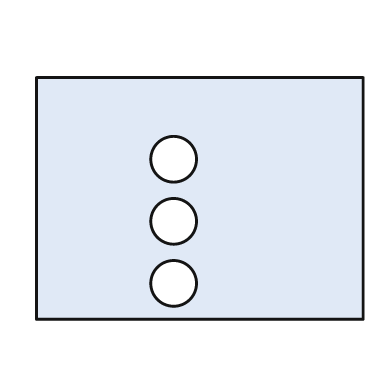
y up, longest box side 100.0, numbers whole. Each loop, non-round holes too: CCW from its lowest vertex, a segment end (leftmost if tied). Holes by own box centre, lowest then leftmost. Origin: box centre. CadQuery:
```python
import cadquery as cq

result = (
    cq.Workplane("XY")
    .moveTo(-50.0, -37.0)
    .lineTo(50.0, -37.0)
    .lineTo(50.0, 37.0)
    .lineTo(-50.0, 37.0)
    .close()
    .moveTo(-8.0, -26.0)
    .circle(7.0)
    .moveTo(-8.0, -7.0)
    .circle(7.0)
    .moveTo(-8.0, 12.0)
    .circle(7.0)
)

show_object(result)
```